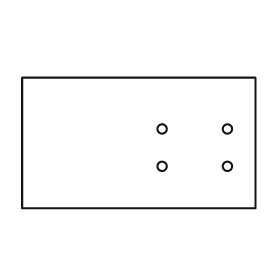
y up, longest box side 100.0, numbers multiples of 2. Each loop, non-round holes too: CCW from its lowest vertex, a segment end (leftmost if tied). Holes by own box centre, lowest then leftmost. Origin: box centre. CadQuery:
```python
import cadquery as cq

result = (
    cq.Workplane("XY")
    .moveTo(-50.0, -28.0)
    .lineTo(50.0, -28.0)
    .lineTo(50.0, 28.0)
    .lineTo(-50.0, 28.0)
    .close()
    .moveTo(10.0, -10.0)
    .circle(2.0)
    .moveTo(38.0, -10.0)
    .circle(2.0)
    .moveTo(10.0, 6.0)
    .circle(2.0)
    .moveTo(38.0, 6.0)
    .circle(2.0)
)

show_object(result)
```